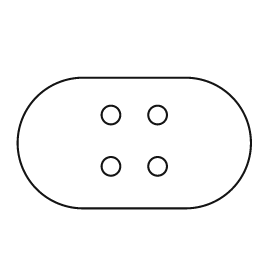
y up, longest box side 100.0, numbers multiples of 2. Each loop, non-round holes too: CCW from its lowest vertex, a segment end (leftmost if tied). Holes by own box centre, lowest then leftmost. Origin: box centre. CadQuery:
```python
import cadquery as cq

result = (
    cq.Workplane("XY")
    .moveTo(-22.0, -28.0)
    .lineTo(22.0, -28.0)
    .threePointArc((50.0, 0.0), (22.0, 28.0))
    .lineTo(-22.0, 28.0)
    .threePointArc((-50.0, 0.0), (-22.0, -28.0))
    .close()
    .moveTo(-10.0, -10.0)
    .circle(4.0)
    .moveTo(10.0, -10.0)
    .circle(4.0)
    .moveTo(-10.0, 12.0)
    .circle(4.0)
    .moveTo(10.0, 12.0)
    .circle(4.0)
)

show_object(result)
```